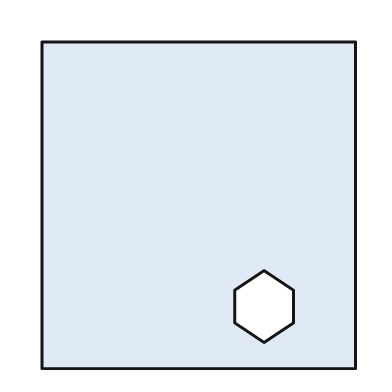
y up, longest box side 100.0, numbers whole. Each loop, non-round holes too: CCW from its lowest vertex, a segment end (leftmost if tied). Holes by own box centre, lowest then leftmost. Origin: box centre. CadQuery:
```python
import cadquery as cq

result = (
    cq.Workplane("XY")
    .moveTo(-48.0, -50.0)
    .lineTo(48.0, -50.0)
    .lineTo(48.0, 50.0)
    .lineTo(-48.0, 50.0)
    .close()
    .moveTo(20.0, -42.0)
    .lineTo(29.0, -36.0)
    .lineTo(29.0, -26.0)
    .lineTo(20.0, -20.0)
    .lineTo(11.0, -26.0)
    .lineTo(11.0, -36.0)
    .close()
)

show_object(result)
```